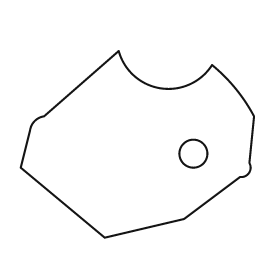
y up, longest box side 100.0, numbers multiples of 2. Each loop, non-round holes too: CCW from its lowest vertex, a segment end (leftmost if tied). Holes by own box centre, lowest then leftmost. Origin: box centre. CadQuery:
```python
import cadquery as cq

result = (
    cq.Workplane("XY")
    .moveTo(-14.0, -40.0)
    .lineTo(20.0, -32.0)
    .lineTo(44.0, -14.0)
    .threePointArc((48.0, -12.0), (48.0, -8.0))
    .lineTo(50.0, 12.0)
    .threePointArc((42.0, 24.0), (32.0, 34.0))
    .threePointArc((10.0, 24.0), (-8.0, 40.0))
    .lineTo(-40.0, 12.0)
    .threePointArc((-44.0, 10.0), (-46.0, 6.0))
    .lineTo(-50.0, -10.0)
    .close()
    .moveTo(24.0, -4.0)
    .circle(6.0)
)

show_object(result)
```